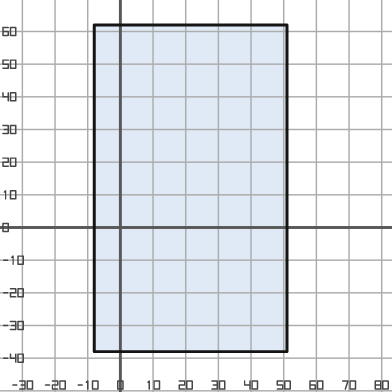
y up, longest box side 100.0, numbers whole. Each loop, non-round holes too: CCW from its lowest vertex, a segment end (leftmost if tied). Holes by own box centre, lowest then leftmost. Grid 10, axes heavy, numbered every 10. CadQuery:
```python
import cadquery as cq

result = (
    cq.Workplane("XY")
    .moveTo(-8.0, -38.0)
    .lineTo(51.0, -38.0)
    .lineTo(51.0, 62.0)
    .lineTo(-8.0, 62.0)
    .close()
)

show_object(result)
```